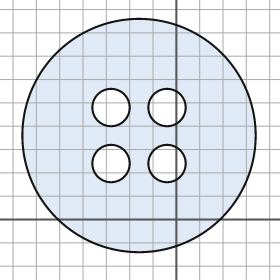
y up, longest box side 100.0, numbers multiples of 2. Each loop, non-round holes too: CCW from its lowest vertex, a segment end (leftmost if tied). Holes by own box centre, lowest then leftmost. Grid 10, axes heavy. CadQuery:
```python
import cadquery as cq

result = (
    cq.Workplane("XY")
    .moveTo(-16.0, 36.0)
    .circle(50.0)
    .moveTo(-28.0, 24.0)
    .circle(8.0)
    .moveTo(-4.0, 24.0)
    .circle(8.0)
    .moveTo(-28.0, 48.0)
    .circle(8.0)
    .moveTo(-4.0, 48.0)
    .circle(8.0)
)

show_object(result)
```